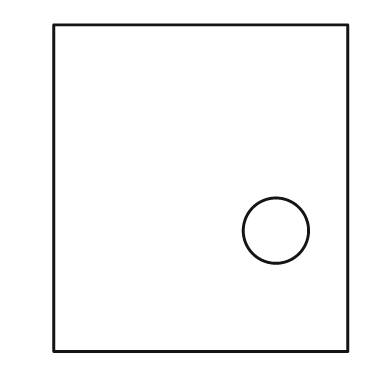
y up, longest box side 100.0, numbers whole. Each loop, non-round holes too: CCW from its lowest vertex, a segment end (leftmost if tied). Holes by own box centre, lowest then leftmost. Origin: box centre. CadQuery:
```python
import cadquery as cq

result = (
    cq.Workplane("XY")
    .moveTo(-45.0, -50.0)
    .lineTo(45.0, -50.0)
    .lineTo(45.0, 50.0)
    .lineTo(-45.0, 50.0)
    .close()
    .moveTo(23.0, -13.0)
    .circle(10.0)
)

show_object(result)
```